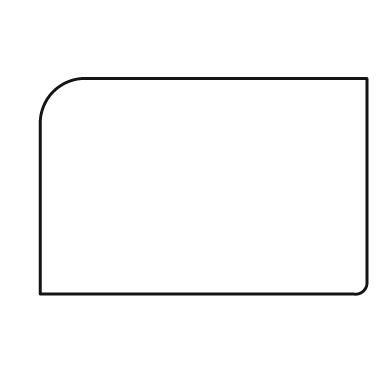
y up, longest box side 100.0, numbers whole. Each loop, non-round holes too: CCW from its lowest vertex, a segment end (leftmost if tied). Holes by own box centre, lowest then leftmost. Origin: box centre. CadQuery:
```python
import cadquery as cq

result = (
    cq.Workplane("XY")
    .moveTo(-50.0, -33.0)
    .lineTo(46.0, -33.0)
    .threePointArc((49.0, -32.0), (50.0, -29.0))
    .lineTo(50.0, 33.0)
    .lineTo(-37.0, 33.0)
    .threePointArc((-46.0, 29.0), (-50.0, 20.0))
    .close()
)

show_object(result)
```